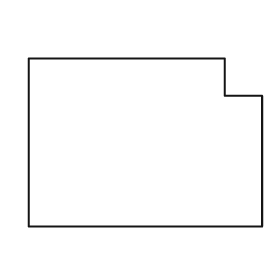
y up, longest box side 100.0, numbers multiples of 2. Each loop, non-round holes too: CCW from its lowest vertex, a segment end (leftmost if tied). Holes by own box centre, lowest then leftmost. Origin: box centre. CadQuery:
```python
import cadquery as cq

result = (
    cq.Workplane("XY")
    .moveTo(-50.0, -36.0)
    .lineTo(50.0, -36.0)
    .lineTo(50.0, 20.0)
    .lineTo(34.0, 20.0)
    .lineTo(34.0, 36.0)
    .lineTo(-50.0, 36.0)
    .close()
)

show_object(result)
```